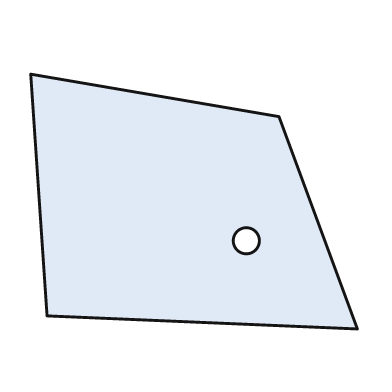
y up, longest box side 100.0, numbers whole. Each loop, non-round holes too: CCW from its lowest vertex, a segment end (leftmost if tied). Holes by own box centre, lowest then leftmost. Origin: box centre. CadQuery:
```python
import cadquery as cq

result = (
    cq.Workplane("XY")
    .moveTo(50.0, -39.0)
    .lineTo(26.0, 26.0)
    .lineTo(-50.0, 39.0)
    .lineTo(-45.0, -35.0)
    .close()
    .moveTo(16.0, -12.0)
    .circle(4.0)
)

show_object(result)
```